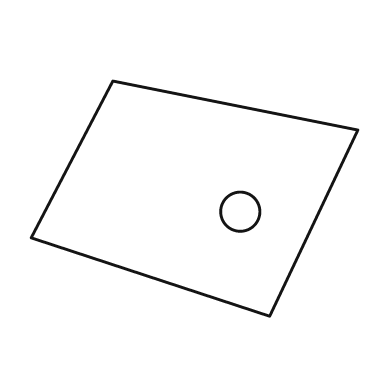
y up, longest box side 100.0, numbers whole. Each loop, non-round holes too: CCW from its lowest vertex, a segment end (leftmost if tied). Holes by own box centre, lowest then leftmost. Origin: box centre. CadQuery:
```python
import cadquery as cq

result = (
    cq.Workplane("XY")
    .moveTo(23.0, -36.0)
    .lineTo(50.0, 21.0)
    .lineTo(-25.0, 36.0)
    .lineTo(-50.0, -12.0)
    .close()
    .moveTo(14.0, -4.0)
    .circle(6.0)
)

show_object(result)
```